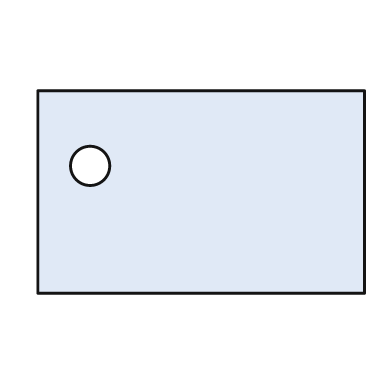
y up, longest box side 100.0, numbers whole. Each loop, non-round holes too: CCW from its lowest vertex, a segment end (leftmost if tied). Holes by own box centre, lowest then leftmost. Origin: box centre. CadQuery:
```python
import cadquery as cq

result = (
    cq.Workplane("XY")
    .moveTo(-50.0, -31.0)
    .lineTo(50.0, -31.0)
    .lineTo(50.0, 31.0)
    .lineTo(-50.0, 31.0)
    .close()
    .moveTo(-34.0, 8.0)
    .circle(6.0)
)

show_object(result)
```